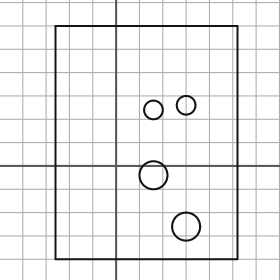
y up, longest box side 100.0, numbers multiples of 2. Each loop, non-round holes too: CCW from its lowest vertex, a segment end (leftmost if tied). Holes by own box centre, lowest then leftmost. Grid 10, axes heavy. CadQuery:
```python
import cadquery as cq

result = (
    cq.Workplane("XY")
    .moveTo(-26.0, -40.0)
    .lineTo(52.0, -40.0)
    .lineTo(52.0, 60.0)
    .lineTo(-26.0, 60.0)
    .close()
    .moveTo(30.0, -26.0)
    .circle(6.0)
    .moveTo(16.0, -4.0)
    .circle(6.0)
    .moveTo(16.0, 24.0)
    .circle(4.0)
    .moveTo(30.0, 26.0)
    .circle(4.0)
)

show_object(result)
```